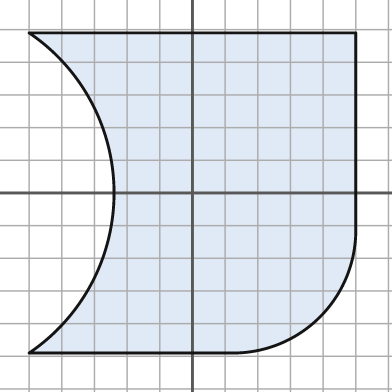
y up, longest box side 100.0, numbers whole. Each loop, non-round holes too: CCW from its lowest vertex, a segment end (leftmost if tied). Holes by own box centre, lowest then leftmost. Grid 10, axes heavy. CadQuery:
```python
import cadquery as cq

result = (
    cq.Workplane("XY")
    .moveTo(-50.0, -49.0)
    .lineTo(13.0, -49.0)
    .threePointArc((39.0, -38.0), (50.0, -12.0))
    .lineTo(50.0, 49.0)
    .lineTo(-50.0, 49.0)
    .threePointArc((-24.0, 0.0), (-50.0, -49.0))
    .close()
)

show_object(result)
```